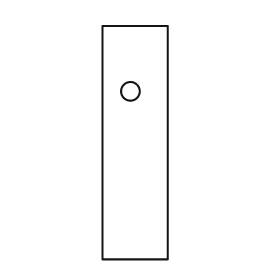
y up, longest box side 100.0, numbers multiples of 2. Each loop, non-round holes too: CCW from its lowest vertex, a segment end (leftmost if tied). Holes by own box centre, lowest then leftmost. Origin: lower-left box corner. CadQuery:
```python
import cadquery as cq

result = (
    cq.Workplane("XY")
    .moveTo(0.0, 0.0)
    .lineTo(28.0, 0.0)
    .lineTo(28.0, 100.0)
    .lineTo(0.0, 100.0)
    .close()
    .moveTo(12.0, 72.0)
    .circle(4.0)
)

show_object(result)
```